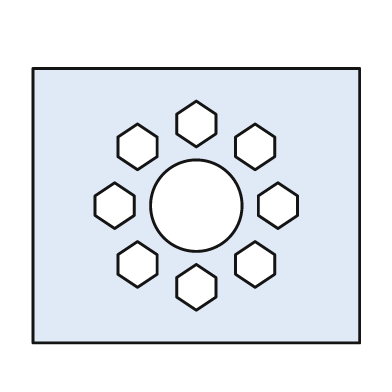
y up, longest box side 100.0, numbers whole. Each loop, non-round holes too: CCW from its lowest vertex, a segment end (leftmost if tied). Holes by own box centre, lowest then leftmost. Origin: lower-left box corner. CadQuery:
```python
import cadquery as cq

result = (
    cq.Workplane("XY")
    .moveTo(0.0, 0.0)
    .lineTo(100.0, 0.0)
    .lineTo(100.0, 84.0)
    .lineTo(0.0, 84.0)
    .close()
    .moveTo(50.0, 10.0)
    .lineTo(56.0, 14.0)
    .lineTo(56.0, 20.0)
    .lineTo(50.0, 24.0)
    .lineTo(44.0, 20.0)
    .lineTo(44.0, 14.0)
    .close()
    .moveTo(32.0, 17.0)
    .lineTo(38.0, 21.0)
    .lineTo(38.0, 27.0)
    .lineTo(32.0, 31.0)
    .lineTo(26.0, 27.0)
    .lineTo(26.0, 21.0)
    .close()
    .moveTo(68.0, 17.0)
    .lineTo(74.0, 21.0)
    .lineTo(74.0, 27.0)
    .lineTo(68.0, 31.0)
    .lineTo(62.0, 27.0)
    .lineTo(62.0, 21.0)
    .close()
    .moveTo(25.0, 35.0)
    .lineTo(31.0, 39.0)
    .lineTo(31.0, 45.0)
    .lineTo(25.0, 49.0)
    .lineTo(19.0, 45.0)
    .lineTo(19.0, 39.0)
    .close()
    .moveTo(50.0, 42.0)
    .circle(14.0)
    .moveTo(75.0, 35.0)
    .lineTo(81.0, 39.0)
    .lineTo(81.0, 45.0)
    .lineTo(75.0, 49.0)
    .lineTo(69.0, 45.0)
    .lineTo(69.0, 39.0)
    .close()
    .moveTo(32.0, 53.0)
    .lineTo(38.0, 57.0)
    .lineTo(38.0, 63.0)
    .lineTo(32.0, 67.0)
    .lineTo(26.0, 63.0)
    .lineTo(26.0, 57.0)
    .close()
    .moveTo(68.0, 53.0)
    .lineTo(74.0, 57.0)
    .lineTo(74.0, 63.0)
    .lineTo(68.0, 67.0)
    .lineTo(62.0, 63.0)
    .lineTo(62.0, 57.0)
    .close()
    .moveTo(50.0, 60.0)
    .lineTo(56.0, 64.0)
    .lineTo(56.0, 70.0)
    .lineTo(50.0, 74.0)
    .lineTo(44.0, 70.0)
    .lineTo(44.0, 64.0)
    .close()
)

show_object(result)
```